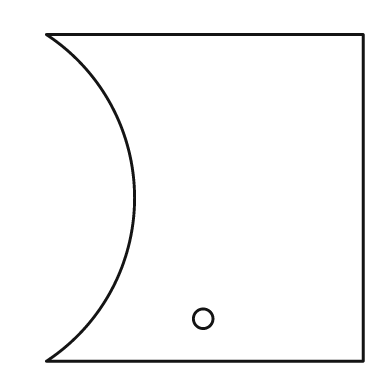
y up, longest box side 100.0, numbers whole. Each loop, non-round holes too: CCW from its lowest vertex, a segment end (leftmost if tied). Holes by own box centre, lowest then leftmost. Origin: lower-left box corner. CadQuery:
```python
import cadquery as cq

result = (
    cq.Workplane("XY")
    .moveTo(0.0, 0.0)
    .lineTo(97.0, 0.0)
    .lineTo(97.0, 100.0)
    .lineTo(0.0, 100.0)
    .threePointArc((27.0, 50.0), (0.0, 0.0))
    .close()
    .moveTo(48.0, 13.0)
    .circle(3.0)
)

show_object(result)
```